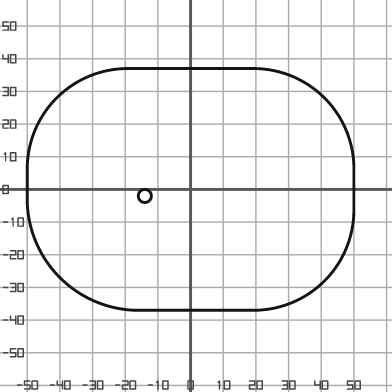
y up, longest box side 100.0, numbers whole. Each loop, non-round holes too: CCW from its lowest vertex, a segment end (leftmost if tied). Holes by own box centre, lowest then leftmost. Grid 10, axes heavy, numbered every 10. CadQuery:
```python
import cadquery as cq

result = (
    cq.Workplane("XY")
    .moveTo(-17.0, -37.0)
    .lineTo(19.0, -37.0)
    .threePointArc((41.0, -28.0), (50.0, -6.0))
    .lineTo(50.0, 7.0)
    .threePointArc((41.0, 28.0), (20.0, 37.0))
    .lineTo(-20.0, 37.0)
    .threePointArc((-41.0, 28.0), (-50.0, 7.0))
    .lineTo(-50.0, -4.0)
    .threePointArc((-40.0, -27.0), (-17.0, -37.0))
    .close()
    .moveTo(-14.0, -2.0)
    .circle(2.0)
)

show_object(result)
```